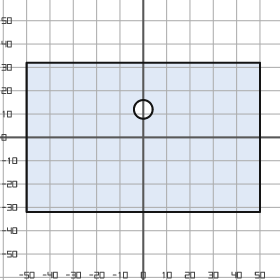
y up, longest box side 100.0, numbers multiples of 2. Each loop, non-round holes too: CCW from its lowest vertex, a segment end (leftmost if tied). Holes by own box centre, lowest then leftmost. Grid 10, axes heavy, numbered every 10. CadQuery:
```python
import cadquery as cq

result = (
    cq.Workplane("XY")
    .moveTo(-50.0, -32.0)
    .lineTo(50.0, -32.0)
    .lineTo(50.0, 32.0)
    .lineTo(-50.0, 32.0)
    .close()
    .moveTo(0.0, 12.0)
    .circle(4.0)
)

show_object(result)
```